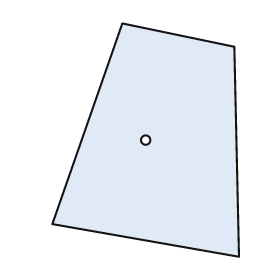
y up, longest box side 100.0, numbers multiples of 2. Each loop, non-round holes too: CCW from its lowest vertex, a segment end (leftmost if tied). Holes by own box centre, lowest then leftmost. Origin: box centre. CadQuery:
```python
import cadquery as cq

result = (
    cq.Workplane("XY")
    .moveTo(40.0, -50.0)
    .lineTo(38.0, 40.0)
    .lineTo(-10.0, 50.0)
    .lineTo(-40.0, -36.0)
    .close()
    .moveTo(0.0, 0.0)
    .circle(2.0)
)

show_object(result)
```